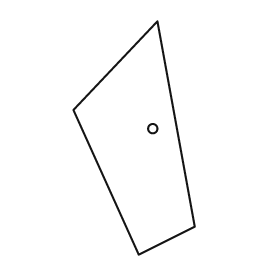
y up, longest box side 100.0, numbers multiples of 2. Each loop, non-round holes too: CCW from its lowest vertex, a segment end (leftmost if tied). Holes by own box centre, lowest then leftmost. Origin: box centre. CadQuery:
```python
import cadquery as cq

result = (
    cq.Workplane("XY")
    .moveTo(2.0, -50.0)
    .lineTo(26.0, -38.0)
    .lineTo(10.0, 50.0)
    .lineTo(-26.0, 12.0)
    .close()
    .moveTo(8.0, 4.0)
    .circle(2.0)
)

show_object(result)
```